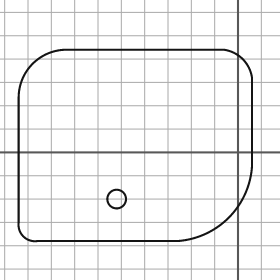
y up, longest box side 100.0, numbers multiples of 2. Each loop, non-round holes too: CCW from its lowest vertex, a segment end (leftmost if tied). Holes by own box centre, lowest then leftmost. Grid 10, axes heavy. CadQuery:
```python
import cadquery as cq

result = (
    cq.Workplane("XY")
    .moveTo(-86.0, -38.0)
    .lineTo(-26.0, -38.0)
    .threePointArc((-4.0, -28.0), (6.0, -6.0))
    .lineTo(6.0, 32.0)
    .threePointArc((2.0, 40.0), (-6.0, 44.0))
    .lineTo(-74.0, 44.0)
    .threePointArc((-88.0, 38.0), (-94.0, 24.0))
    .lineTo(-94.0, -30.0)
    .threePointArc((-92.0, -36.0), (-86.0, -38.0))
    .close()
    .moveTo(-52.0, -20.0)
    .circle(4.0)
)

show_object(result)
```